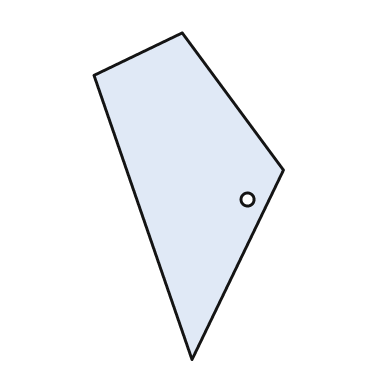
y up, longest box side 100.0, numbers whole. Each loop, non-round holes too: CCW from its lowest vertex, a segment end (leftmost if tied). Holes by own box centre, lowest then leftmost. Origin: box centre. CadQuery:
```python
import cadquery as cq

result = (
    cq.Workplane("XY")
    .moveTo(1.0, -50.0)
    .lineTo(29.0, 8.0)
    .lineTo(-2.0, 50.0)
    .lineTo(-29.0, 37.0)
    .close()
    .moveTo(18.0, -1.0)
    .circle(2.0)
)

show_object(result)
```